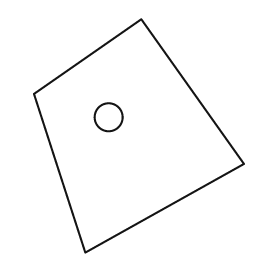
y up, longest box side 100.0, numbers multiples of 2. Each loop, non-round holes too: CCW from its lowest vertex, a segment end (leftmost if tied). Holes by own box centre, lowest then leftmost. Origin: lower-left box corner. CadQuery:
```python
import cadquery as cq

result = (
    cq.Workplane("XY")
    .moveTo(22.0, 0.0)
    .lineTo(90.0, 38.0)
    .lineTo(46.0, 100.0)
    .lineTo(0.0, 68.0)
    .close()
    .moveTo(32.0, 58.0)
    .circle(6.0)
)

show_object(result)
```